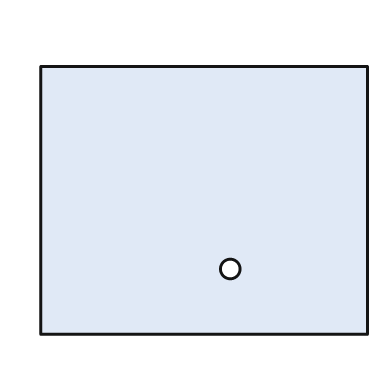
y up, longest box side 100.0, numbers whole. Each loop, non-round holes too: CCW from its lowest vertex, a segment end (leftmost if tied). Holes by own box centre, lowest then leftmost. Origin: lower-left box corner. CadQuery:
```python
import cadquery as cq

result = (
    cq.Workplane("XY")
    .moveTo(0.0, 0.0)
    .lineTo(100.0, 0.0)
    .lineTo(100.0, 82.0)
    .lineTo(0.0, 82.0)
    .close()
    .moveTo(58.0, 20.0)
    .circle(3.0)
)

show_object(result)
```